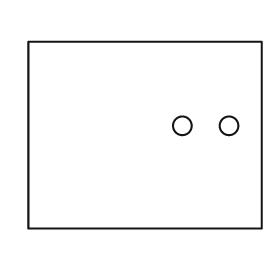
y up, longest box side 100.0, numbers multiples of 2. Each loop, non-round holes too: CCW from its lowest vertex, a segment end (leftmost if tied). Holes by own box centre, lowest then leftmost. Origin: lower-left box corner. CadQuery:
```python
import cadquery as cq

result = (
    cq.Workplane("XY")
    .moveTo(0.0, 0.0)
    .lineTo(100.0, 0.0)
    .lineTo(100.0, 80.0)
    .lineTo(0.0, 80.0)
    .close()
    .moveTo(66.0, 44.0)
    .circle(4.0)
    .moveTo(86.0, 44.0)
    .circle(4.0)
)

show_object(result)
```